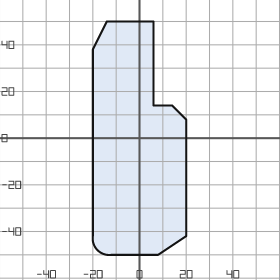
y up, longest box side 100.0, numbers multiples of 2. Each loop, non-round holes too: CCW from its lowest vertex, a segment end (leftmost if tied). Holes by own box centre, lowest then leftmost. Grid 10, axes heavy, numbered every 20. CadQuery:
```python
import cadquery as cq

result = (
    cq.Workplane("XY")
    .moveTo(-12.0, -50.0)
    .lineTo(8.0, -50.0)
    .lineTo(20.0, -42.0)
    .lineTo(20.0, 8.0)
    .lineTo(14.0, 14.0)
    .lineTo(6.0, 14.0)
    .lineTo(6.0, 50.0)
    .lineTo(-14.0, 50.0)
    .lineTo(-20.0, 38.0)
    .lineTo(-20.0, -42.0)
    .threePointArc((-18.0, -48.0), (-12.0, -50.0))
    .close()
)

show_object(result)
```